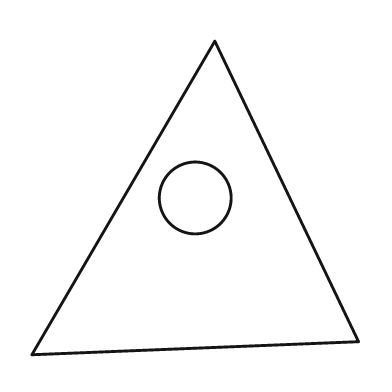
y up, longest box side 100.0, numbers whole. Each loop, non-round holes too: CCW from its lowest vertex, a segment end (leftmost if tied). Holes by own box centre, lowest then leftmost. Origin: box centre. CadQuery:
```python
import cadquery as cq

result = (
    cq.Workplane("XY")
    .moveTo(-50.0, -48.0)
    .lineTo(50.0, -44.0)
    .lineTo(6.0, 48.0)
    .close()
    .moveTo(0.0, 0.0)
    .circle(11.0)
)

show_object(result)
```